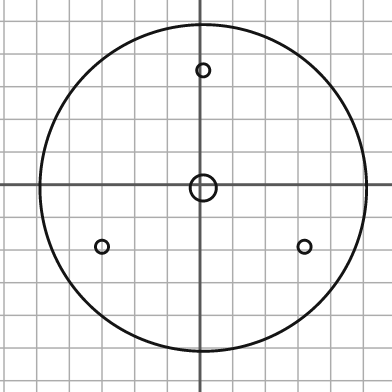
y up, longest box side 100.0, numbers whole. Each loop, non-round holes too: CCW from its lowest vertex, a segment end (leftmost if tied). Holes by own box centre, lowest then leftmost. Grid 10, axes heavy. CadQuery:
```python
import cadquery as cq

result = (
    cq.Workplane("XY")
    .moveTo(1.0, -1.0)
    .circle(50.0)
    .moveTo(-30.0, -19.0)
    .circle(2.0)
    .moveTo(32.0, -19.0)
    .circle(2.0)
    .moveTo(1.0, -1.0)
    .circle(4.0)
    .moveTo(1.0, 35.0)
    .circle(2.0)
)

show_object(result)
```